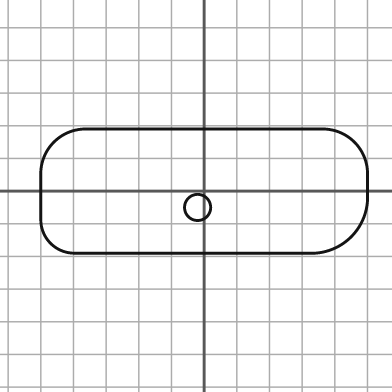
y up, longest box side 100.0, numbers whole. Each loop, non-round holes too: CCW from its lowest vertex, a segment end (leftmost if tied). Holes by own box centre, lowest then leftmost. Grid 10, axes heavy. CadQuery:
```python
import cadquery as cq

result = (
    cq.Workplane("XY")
    .moveTo(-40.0, -19.0)
    .lineTo(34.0, -19.0)
    .threePointArc((45.0, -14.0), (50.0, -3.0))
    .lineTo(50.0, 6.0)
    .threePointArc((46.0, 15.0), (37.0, 19.0))
    .lineTo(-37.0, 19.0)
    .threePointArc((-46.0, 15.0), (-50.0, 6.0))
    .lineTo(-50.0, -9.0)
    .threePointArc((-47.0, -16.0), (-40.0, -19.0))
    .close()
    .moveTo(-2.0, -5.0)
    .circle(4.0)
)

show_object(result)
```